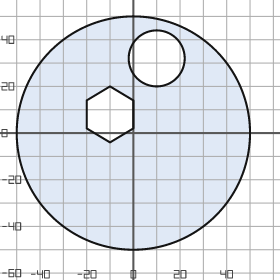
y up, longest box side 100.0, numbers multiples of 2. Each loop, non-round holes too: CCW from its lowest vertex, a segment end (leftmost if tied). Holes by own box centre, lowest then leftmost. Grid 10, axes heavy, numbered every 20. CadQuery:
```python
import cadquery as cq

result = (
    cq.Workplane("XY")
    .moveTo(0.0, 0.0)
    .circle(50.0)
    .moveTo(-10.0, -4.0)
    .lineTo(0.0, 2.0)
    .lineTo(0.0, 14.0)
    .lineTo(-10.0, 20.0)
    .lineTo(-20.0, 14.0)
    .lineTo(-20.0, 2.0)
    .close()
    .moveTo(10.0, 32.0)
    .circle(12.0)
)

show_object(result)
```